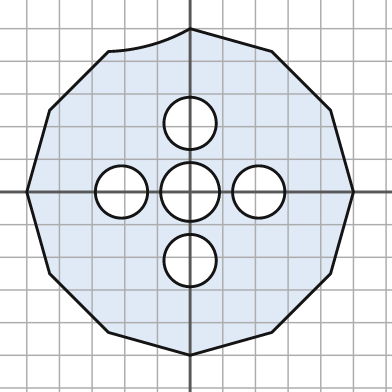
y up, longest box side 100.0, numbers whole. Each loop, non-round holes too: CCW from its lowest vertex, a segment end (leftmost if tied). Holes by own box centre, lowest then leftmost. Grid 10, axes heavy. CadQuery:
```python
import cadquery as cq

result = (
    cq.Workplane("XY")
    .moveTo(0.0, -50.0)
    .lineTo(25.0, -43.0)
    .lineTo(43.0, -25.0)
    .lineTo(50.0, 0.0)
    .lineTo(43.0, 25.0)
    .lineTo(25.0, 43.0)
    .lineTo(0.0, 50.0)
    .threePointArc((-12.0, 45.0), (-25.0, 43.0))
    .lineTo(-43.0, 25.0)
    .lineTo(-50.0, 0.0)
    .lineTo(-43.0, -25.0)
    .lineTo(-25.0, -43.0)
    .close()
    .moveTo(0.0, -21.0)
    .circle(8.0)
    .moveTo(-21.0, 0.0)
    .circle(8.0)
    .moveTo(0.0, 0.0)
    .circle(9.0)
    .moveTo(21.0, 0.0)
    .circle(8.0)
    .moveTo(0.0, 21.0)
    .circle(8.0)
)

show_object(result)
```